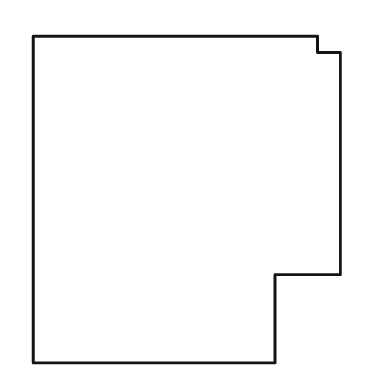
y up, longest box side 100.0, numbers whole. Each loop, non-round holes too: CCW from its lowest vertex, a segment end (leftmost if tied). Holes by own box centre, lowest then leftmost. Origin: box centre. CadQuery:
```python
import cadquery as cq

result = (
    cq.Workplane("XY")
    .moveTo(-47.0, -50.0)
    .lineTo(27.0, -50.0)
    .lineTo(27.0, -23.0)
    .lineTo(47.0, -23.0)
    .lineTo(47.0, 45.0)
    .lineTo(40.0, 45.0)
    .lineTo(40.0, 50.0)
    .lineTo(-47.0, 50.0)
    .close()
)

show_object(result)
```